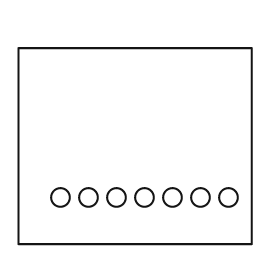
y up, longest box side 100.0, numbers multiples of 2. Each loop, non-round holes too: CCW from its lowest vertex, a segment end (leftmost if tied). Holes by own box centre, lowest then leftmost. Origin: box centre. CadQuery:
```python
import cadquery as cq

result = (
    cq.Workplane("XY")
    .moveTo(-50.0, -42.0)
    .lineTo(50.0, -42.0)
    .lineTo(50.0, 42.0)
    .lineTo(-50.0, 42.0)
    .close()
    .moveTo(-32.0, -22.0)
    .circle(4.0)
    .moveTo(-20.0, -22.0)
    .circle(4.0)
    .moveTo(-8.0, -22.0)
    .circle(4.0)
    .moveTo(4.0, -22.0)
    .circle(4.0)
    .moveTo(16.0, -22.0)
    .circle(4.0)
    .moveTo(28.0, -22.0)
    .circle(4.0)
    .moveTo(40.0, -22.0)
    .circle(4.0)
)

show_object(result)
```